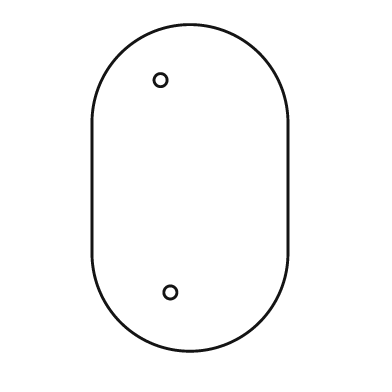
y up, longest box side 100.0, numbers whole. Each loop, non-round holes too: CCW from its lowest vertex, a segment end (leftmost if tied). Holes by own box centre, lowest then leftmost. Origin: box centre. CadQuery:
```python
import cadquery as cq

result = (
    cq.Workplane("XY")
    .moveTo(-30.0, -20.0)
    .threePointArc((0.0, -50.0), (30.0, -20.0))
    .lineTo(30.0, 20.0)
    .threePointArc((0.0, 50.0), (-30.0, 20.0))
    .close()
    .moveTo(-6.0, -32.0)
    .circle(2.0)
    .moveTo(-9.0, 33.0)
    .circle(2.0)
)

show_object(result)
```